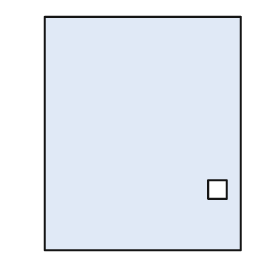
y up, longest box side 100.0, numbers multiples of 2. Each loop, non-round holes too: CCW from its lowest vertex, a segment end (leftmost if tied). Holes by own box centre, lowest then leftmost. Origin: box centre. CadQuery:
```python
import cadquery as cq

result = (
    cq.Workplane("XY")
    .moveTo(-42.0, -50.0)
    .lineTo(42.0, -50.0)
    .lineTo(42.0, 50.0)
    .lineTo(-42.0, 50.0)
    .close()
    .moveTo(28.0, -28.0)
    .lineTo(36.0, -28.0)
    .lineTo(36.0, -20.0)
    .lineTo(28.0, -20.0)
    .close()
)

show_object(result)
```